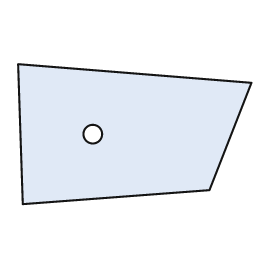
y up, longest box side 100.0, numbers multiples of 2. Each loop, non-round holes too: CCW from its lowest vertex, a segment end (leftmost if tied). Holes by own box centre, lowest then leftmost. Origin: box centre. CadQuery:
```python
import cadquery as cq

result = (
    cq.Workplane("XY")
    .moveTo(-48.0, -30.0)
    .lineTo(32.0, -24.0)
    .lineTo(50.0, 22.0)
    .lineTo(-50.0, 30.0)
    .close()
    .moveTo(-18.0, 0.0)
    .circle(4.0)
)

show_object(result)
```